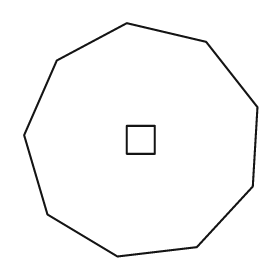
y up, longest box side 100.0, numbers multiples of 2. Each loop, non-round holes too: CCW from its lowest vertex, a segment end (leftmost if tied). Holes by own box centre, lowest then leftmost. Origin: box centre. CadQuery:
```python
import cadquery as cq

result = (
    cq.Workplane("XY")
    .moveTo(-10.0, -50.0)
    .lineTo(24.0, -46.0)
    .lineTo(48.0, -20.0)
    .lineTo(50.0, 14.0)
    .lineTo(28.0, 42.0)
    .lineTo(-6.0, 50.0)
    .lineTo(-36.0, 34.0)
    .lineTo(-50.0, 2.0)
    .lineTo(-40.0, -32.0)
    .close()
    .moveTo(-6.0, -6.0)
    .lineTo(6.0, -6.0)
    .lineTo(6.0, 6.0)
    .lineTo(-6.0, 6.0)
    .close()
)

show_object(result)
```